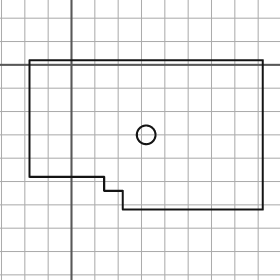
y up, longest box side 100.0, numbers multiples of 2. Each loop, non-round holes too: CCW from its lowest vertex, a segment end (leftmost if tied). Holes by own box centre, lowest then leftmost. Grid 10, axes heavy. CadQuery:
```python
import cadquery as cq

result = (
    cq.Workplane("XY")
    .moveTo(22.0, -62.0)
    .lineTo(82.0, -62.0)
    .lineTo(82.0, 2.0)
    .lineTo(-18.0, 2.0)
    .lineTo(-18.0, -48.0)
    .lineTo(14.0, -48.0)
    .lineTo(14.0, -54.0)
    .lineTo(22.0, -54.0)
    .close()
    .moveTo(32.0, -30.0)
    .circle(4.0)
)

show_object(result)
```